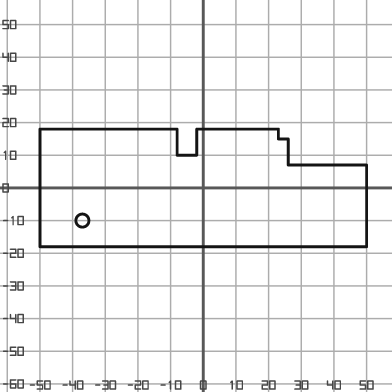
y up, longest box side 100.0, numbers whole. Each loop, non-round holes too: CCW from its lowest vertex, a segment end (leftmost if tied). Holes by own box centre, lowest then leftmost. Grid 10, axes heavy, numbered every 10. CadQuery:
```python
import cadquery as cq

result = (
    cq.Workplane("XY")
    .moveTo(-50.0, -18.0)
    .lineTo(50.0, -18.0)
    .lineTo(50.0, 7.0)
    .lineTo(26.0, 7.0)
    .lineTo(26.0, 15.0)
    .lineTo(23.0, 15.0)
    .lineTo(23.0, 18.0)
    .lineTo(-2.0, 18.0)
    .lineTo(-2.0, 10.0)
    .lineTo(-8.0, 10.0)
    .lineTo(-8.0, 18.0)
    .lineTo(-50.0, 18.0)
    .close()
    .moveTo(-37.0, -10.0)
    .circle(2.0)
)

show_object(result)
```